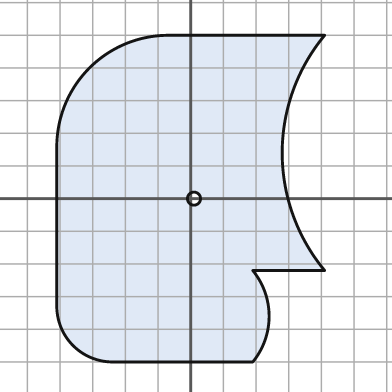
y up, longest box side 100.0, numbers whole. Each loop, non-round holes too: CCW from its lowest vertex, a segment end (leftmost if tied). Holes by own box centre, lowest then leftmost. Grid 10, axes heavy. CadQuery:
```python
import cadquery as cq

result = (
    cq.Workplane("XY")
    .moveTo(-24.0, -50.0)
    .lineTo(19.0, -50.0)
    .threePointArc((24.0, -36.0), (19.0, -22.0))
    .lineTo(41.0, -22.0)
    .threePointArc((28.0, 14.0), (41.0, 50.0))
    .lineTo(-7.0, 50.0)
    .threePointArc((-31.0, 40.0), (-41.0, 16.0))
    .lineTo(-41.0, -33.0)
    .threePointArc((-36.0, -45.0), (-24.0, -50.0))
    .close()
    .moveTo(1.0, 0.0)
    .circle(2.0)
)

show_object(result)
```